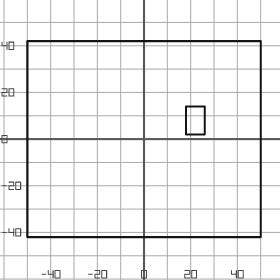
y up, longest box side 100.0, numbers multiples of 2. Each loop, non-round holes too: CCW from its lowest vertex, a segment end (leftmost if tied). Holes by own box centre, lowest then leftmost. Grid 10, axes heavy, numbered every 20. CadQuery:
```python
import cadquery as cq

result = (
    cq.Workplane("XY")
    .moveTo(-50.0, -42.0)
    .lineTo(50.0, -42.0)
    .lineTo(50.0, 42.0)
    .lineTo(-50.0, 42.0)
    .close()
    .moveTo(18.0, 2.0)
    .lineTo(26.0, 2.0)
    .lineTo(26.0, 14.0)
    .lineTo(18.0, 14.0)
    .close()
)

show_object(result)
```